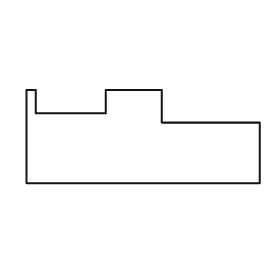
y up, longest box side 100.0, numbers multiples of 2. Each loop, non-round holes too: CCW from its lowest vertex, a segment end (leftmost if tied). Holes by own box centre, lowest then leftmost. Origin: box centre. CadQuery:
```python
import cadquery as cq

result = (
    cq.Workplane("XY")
    .moveTo(-50.0, -20.0)
    .lineTo(50.0, -20.0)
    .lineTo(50.0, 6.0)
    .lineTo(8.0, 6.0)
    .lineTo(8.0, 20.0)
    .lineTo(-16.0, 20.0)
    .lineTo(-16.0, 10.0)
    .lineTo(-46.0, 10.0)
    .lineTo(-46.0, 20.0)
    .lineTo(-50.0, 20.0)
    .close()
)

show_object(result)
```